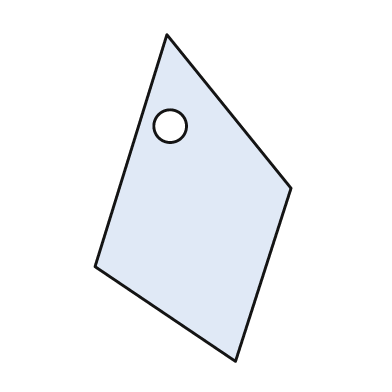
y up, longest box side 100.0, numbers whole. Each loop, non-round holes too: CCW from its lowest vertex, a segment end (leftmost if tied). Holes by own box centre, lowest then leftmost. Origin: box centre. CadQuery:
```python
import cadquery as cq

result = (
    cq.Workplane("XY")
    .moveTo(13.0, -50.0)
    .lineTo(30.0, 3.0)
    .lineTo(-8.0, 50.0)
    .lineTo(-30.0, -21.0)
    .close()
    .moveTo(-7.0, 22.0)
    .circle(5.0)
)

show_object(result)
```